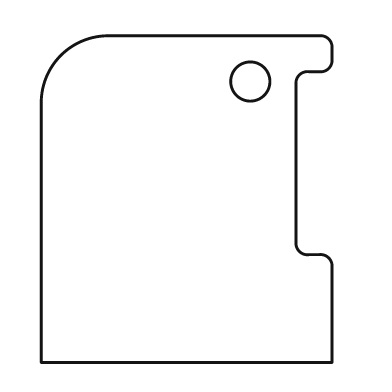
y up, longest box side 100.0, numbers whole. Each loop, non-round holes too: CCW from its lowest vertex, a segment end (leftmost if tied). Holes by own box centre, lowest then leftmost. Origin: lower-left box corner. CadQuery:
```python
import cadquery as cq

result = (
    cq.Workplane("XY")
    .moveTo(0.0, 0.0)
    .lineTo(89.0, 0.0)
    .lineTo(89.0, 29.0)
    .threePointArc((88.0, 32.0), (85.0, 33.0))
    .lineTo(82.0, 33.0)
    .threePointArc((79.0, 34.0), (78.0, 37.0))
    .lineTo(78.0, 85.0)
    .threePointArc((79.0, 88.0), (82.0, 89.0))
    .lineTo(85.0, 89.0)
    .threePointArc((88.0, 90.0), (89.0, 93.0))
    .lineTo(89.0, 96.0)
    .threePointArc((88.0, 99.0), (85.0, 100.0))
    .lineTo(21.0, 100.0)
    .threePointArc((6.0, 94.0), (0.0, 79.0))
    .close()
    .moveTo(64.0, 86.0)
    .circle(6.0)
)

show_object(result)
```